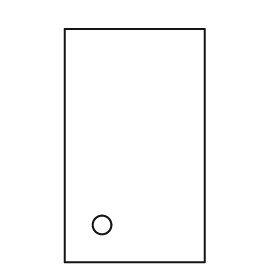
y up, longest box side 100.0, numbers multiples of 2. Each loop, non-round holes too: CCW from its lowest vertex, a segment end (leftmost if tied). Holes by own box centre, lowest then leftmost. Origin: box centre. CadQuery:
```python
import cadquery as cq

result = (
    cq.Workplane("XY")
    .moveTo(-30.0, -50.0)
    .lineTo(30.0, -50.0)
    .lineTo(30.0, 50.0)
    .lineTo(-30.0, 50.0)
    .close()
    .moveTo(-14.0, -34.0)
    .circle(4.0)
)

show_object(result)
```